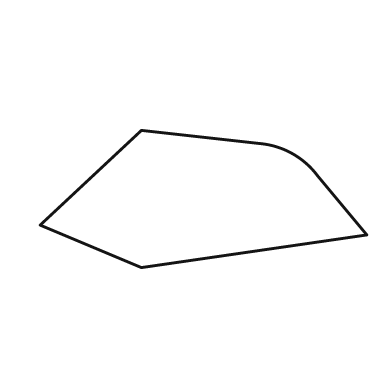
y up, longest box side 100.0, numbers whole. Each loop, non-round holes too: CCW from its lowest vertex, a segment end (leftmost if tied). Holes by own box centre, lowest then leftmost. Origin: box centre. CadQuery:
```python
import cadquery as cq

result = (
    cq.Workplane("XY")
    .moveTo(-19.0, -21.0)
    .lineTo(50.0, -11.0)
    .lineTo(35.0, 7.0)
    .threePointArc((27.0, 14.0), (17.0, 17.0))
    .lineTo(-19.0, 21.0)
    .lineTo(-50.0, -8.0)
    .close()
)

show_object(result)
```